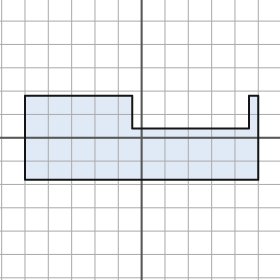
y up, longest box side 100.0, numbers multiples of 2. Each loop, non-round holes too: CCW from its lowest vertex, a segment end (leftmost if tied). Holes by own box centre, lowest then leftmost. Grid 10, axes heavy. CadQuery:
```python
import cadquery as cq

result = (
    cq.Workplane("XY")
    .moveTo(-50.0, -18.0)
    .lineTo(50.0, -18.0)
    .lineTo(50.0, 18.0)
    .lineTo(46.0, 18.0)
    .lineTo(46.0, 4.0)
    .lineTo(-4.0, 4.0)
    .lineTo(-4.0, 18.0)
    .lineTo(-50.0, 18.0)
    .close()
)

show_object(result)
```